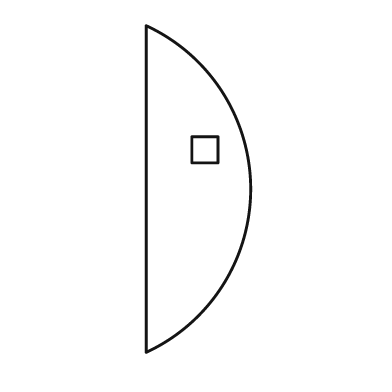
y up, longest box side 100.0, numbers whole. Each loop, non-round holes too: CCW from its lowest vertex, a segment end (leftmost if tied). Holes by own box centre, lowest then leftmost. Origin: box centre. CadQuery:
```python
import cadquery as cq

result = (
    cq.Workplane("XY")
    .moveTo(-16.0, -50.0)
    .threePointArc((16.0, 0.0), (-16.0, 50.0))
    .close()
    .moveTo(-2.0, 8.0)
    .lineTo(6.0, 8.0)
    .lineTo(6.0, 16.0)
    .lineTo(-2.0, 16.0)
    .close()
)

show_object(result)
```